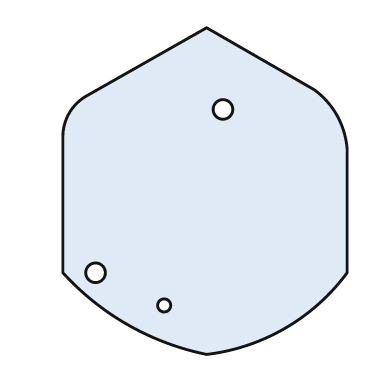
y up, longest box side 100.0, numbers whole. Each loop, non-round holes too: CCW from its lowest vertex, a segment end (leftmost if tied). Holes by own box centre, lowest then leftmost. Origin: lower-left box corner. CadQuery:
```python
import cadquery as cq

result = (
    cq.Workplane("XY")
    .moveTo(44.0, 0.0)
    .threePointArc((68.0, 8.0), (87.0, 25.0))
    .lineTo(87.0, 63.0)
    .threePointArc((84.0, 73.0), (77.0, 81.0))
    .lineTo(44.0, 100.0)
    .lineTo(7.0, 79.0)
    .threePointArc((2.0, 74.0), (0.0, 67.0))
    .lineTo(0.0, 25.0)
    .threePointArc((20.0, 9.0), (44.0, 0.0))
    .close()
    .moveTo(31.0, 15.0)
    .circle(2.0)
    .moveTo(10.0, 25.0)
    .circle(3.0)
    .moveTo(49.0, 75.0)
    .circle(3.0)
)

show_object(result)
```